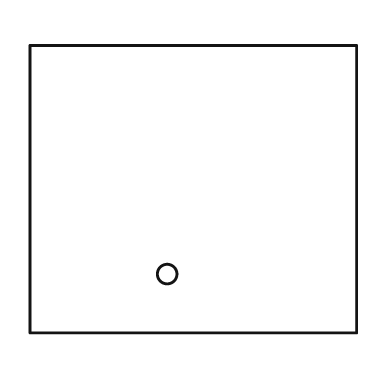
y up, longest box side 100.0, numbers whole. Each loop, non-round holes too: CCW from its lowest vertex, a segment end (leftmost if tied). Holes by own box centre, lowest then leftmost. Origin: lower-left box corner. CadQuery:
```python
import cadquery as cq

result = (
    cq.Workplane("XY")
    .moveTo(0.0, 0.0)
    .lineTo(100.0, 0.0)
    .lineTo(100.0, 88.0)
    .lineTo(0.0, 88.0)
    .close()
    .moveTo(42.0, 18.0)
    .circle(3.0)
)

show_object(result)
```